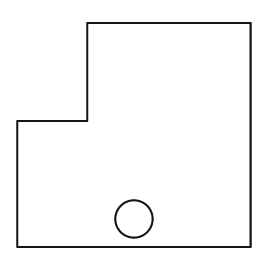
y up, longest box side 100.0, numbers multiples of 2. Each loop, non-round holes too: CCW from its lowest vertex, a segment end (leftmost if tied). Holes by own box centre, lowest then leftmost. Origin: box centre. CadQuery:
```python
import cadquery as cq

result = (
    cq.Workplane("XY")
    .moveTo(-50.0, -48.0)
    .lineTo(50.0, -48.0)
    .lineTo(50.0, 48.0)
    .lineTo(-20.0, 48.0)
    .lineTo(-20.0, 6.0)
    .lineTo(-50.0, 6.0)
    .close()
    .moveTo(0.0, -36.0)
    .circle(8.0)
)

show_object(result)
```